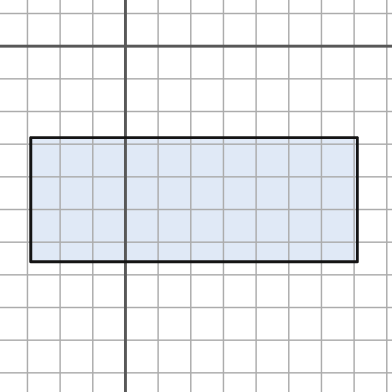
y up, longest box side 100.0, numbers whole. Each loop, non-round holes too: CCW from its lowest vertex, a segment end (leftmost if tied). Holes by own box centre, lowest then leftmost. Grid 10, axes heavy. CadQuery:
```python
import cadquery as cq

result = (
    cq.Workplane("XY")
    .moveTo(-29.0, -66.0)
    .lineTo(71.0, -66.0)
    .lineTo(71.0, -28.0)
    .lineTo(-29.0, -28.0)
    .close()
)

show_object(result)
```